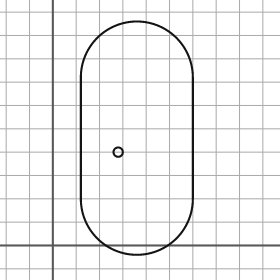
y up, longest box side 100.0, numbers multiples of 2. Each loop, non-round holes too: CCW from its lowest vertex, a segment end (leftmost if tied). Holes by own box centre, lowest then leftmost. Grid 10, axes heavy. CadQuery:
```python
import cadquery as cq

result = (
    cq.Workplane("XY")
    .moveTo(12.0, 20.0)
    .threePointArc((36.0, -4.0), (60.0, 20.0))
    .lineTo(60.0, 72.0)
    .threePointArc((36.0, 96.0), (12.0, 72.0))
    .close()
    .moveTo(28.0, 40.0)
    .circle(2.0)
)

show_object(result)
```